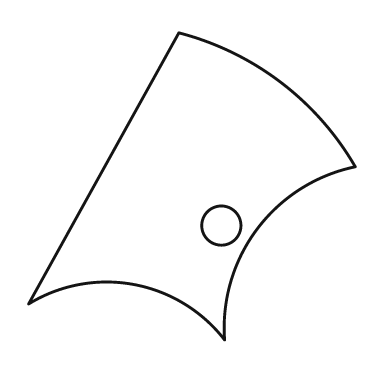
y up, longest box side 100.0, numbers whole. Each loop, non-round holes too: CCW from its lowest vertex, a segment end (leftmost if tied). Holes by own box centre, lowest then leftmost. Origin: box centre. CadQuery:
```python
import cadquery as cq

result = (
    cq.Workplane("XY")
    .moveTo(10.0, -47.0)
    .threePointArc((20.0, -13.0), (50.0, 6.0))
    .threePointArc((27.0, 32.0), (-4.0, 47.0))
    .lineTo(-50.0, -36.0)
    .threePointArc((-18.0, -30.0), (10.0, -47.0))
    .close()
    .moveTo(9.0, -12.0)
    .circle(6.0)
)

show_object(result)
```